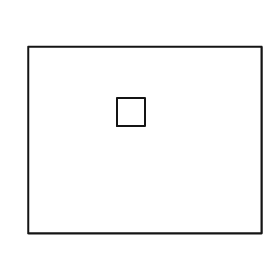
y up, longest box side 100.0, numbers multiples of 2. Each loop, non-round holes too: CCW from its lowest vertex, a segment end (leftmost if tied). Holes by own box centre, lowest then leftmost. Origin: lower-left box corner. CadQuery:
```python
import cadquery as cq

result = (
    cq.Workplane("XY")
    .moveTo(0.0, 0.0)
    .lineTo(100.0, 0.0)
    .lineTo(100.0, 80.0)
    .lineTo(0.0, 80.0)
    .close()
    .moveTo(38.0, 46.0)
    .lineTo(50.0, 46.0)
    .lineTo(50.0, 58.0)
    .lineTo(38.0, 58.0)
    .close()
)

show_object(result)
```